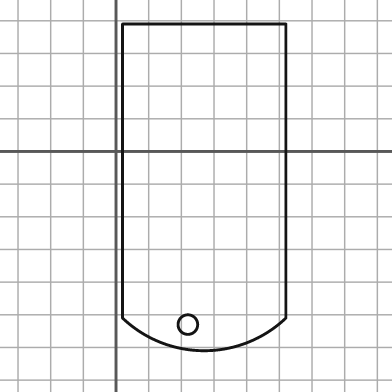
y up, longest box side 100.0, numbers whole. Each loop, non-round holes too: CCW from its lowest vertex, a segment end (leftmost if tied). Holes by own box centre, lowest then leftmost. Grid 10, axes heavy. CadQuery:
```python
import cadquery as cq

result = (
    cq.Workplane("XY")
    .moveTo(2.0, -51.0)
    .threePointArc((27.0, -61.0), (52.0, -51.0))
    .lineTo(52.0, 39.0)
    .lineTo(2.0, 39.0)
    .close()
    .moveTo(22.0, -53.0)
    .circle(3.0)
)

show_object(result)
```